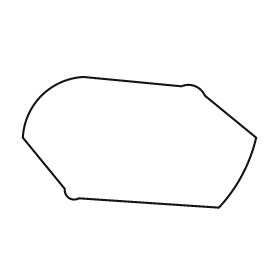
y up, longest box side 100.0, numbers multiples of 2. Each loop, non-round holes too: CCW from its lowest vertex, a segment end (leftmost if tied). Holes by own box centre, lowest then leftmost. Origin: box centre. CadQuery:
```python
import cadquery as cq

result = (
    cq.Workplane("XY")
    .moveTo(34.0, -28.0)
    .threePointArc((44.0, -14.0), (50.0, 2.0))
    .lineTo(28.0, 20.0)
    .threePointArc((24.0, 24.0), (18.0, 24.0))
    .lineTo(-24.0, 28.0)
    .threePointArc((-42.0, 20.0), (-50.0, 2.0))
    .lineTo(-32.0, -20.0)
    .threePointArc((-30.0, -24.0), (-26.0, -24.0))
    .close()
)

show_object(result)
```